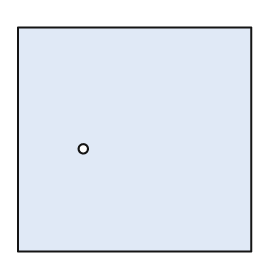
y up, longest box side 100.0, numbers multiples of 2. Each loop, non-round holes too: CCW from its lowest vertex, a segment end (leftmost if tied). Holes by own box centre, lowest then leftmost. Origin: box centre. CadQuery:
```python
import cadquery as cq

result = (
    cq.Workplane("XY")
    .moveTo(-50.0, -48.0)
    .lineTo(50.0, -48.0)
    .lineTo(50.0, 48.0)
    .lineTo(-50.0, 48.0)
    .close()
    .moveTo(-22.0, -4.0)
    .circle(2.0)
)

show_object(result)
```